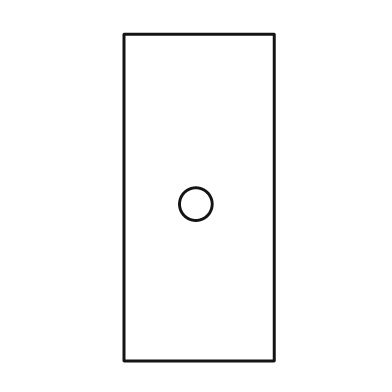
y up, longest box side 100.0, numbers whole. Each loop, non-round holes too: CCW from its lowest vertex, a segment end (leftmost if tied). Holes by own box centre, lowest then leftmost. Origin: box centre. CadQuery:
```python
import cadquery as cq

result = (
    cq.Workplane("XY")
    .moveTo(-23.0, -50.0)
    .lineTo(23.0, -50.0)
    .lineTo(23.0, 50.0)
    .lineTo(-23.0, 50.0)
    .close()
    .moveTo(-1.0, -2.0)
    .circle(5.0)
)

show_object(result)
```